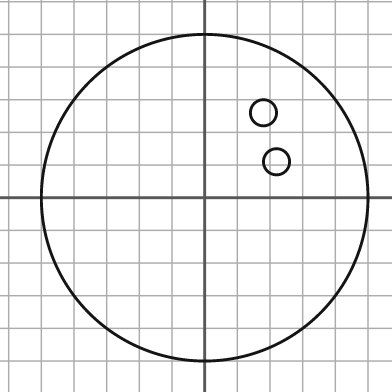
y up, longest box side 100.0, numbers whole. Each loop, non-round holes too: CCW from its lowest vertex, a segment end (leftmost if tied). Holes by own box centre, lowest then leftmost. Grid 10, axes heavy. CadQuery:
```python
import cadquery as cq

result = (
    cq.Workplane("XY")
    .moveTo(0.0, 0.0)
    .circle(50.0)
    .moveTo(22.0, 11.0)
    .circle(4.0)
    .moveTo(18.0, 26.0)
    .circle(4.0)
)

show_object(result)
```